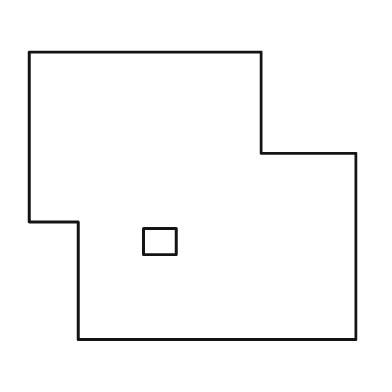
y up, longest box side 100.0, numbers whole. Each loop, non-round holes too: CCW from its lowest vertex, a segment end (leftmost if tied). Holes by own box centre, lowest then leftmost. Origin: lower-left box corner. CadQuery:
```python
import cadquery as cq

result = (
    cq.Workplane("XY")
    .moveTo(15.0, 0.0)
    .lineTo(100.0, 0.0)
    .lineTo(100.0, 57.0)
    .lineTo(71.0, 57.0)
    .lineTo(71.0, 88.0)
    .lineTo(0.0, 88.0)
    .lineTo(0.0, 36.0)
    .lineTo(15.0, 36.0)
    .close()
    .moveTo(35.0, 26.0)
    .lineTo(45.0, 26.0)
    .lineTo(45.0, 34.0)
    .lineTo(35.0, 34.0)
    .close()
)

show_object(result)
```